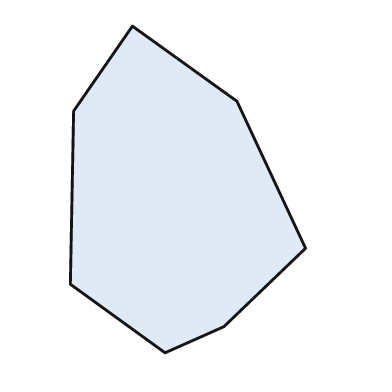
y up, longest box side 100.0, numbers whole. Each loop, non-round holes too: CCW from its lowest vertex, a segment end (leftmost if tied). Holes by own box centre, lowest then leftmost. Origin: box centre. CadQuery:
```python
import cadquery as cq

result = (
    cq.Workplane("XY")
    .moveTo(-7.0, -50.0)
    .lineTo(11.0, -42.0)
    .lineTo(36.0, -18.0)
    .lineTo(15.0, 27.0)
    .lineTo(-17.0, 50.0)
    .lineTo(-35.0, 24.0)
    .lineTo(-36.0, -29.0)
    .close()
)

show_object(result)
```